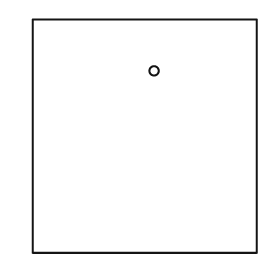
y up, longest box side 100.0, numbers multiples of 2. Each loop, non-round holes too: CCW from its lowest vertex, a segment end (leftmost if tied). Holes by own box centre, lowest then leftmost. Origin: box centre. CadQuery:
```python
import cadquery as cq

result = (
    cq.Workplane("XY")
    .moveTo(-48.0, -50.0)
    .lineTo(48.0, -50.0)
    .lineTo(48.0, 50.0)
    .lineTo(-48.0, 50.0)
    .close()
    .moveTo(4.0, 28.0)
    .circle(2.0)
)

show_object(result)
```